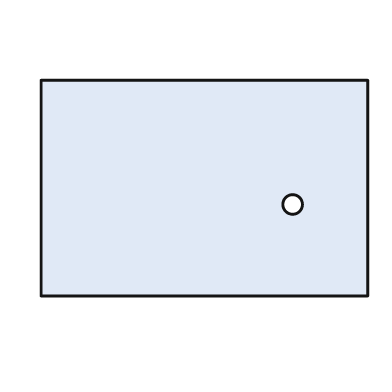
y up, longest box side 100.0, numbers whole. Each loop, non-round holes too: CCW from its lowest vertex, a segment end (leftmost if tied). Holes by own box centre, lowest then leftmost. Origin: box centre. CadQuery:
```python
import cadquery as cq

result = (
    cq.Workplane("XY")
    .moveTo(-50.0, -33.0)
    .lineTo(50.0, -33.0)
    .lineTo(50.0, 33.0)
    .lineTo(-50.0, 33.0)
    .close()
    .moveTo(27.0, -5.0)
    .circle(3.0)
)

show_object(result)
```